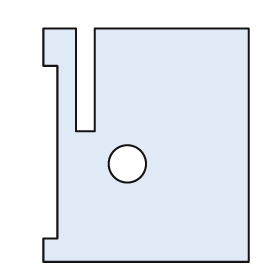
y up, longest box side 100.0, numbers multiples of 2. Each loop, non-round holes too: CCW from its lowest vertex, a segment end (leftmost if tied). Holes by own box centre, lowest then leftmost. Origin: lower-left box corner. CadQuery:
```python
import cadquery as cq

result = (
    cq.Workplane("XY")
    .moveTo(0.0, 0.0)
    .lineTo(88.0, 0.0)
    .lineTo(88.0, 100.0)
    .lineTo(22.0, 100.0)
    .lineTo(22.0, 56.0)
    .lineTo(14.0, 56.0)
    .lineTo(14.0, 100.0)
    .lineTo(0.0, 100.0)
    .lineTo(0.0, 84.0)
    .lineTo(6.0, 84.0)
    .lineTo(6.0, 10.0)
    .lineTo(0.0, 10.0)
    .close()
    .moveTo(36.0, 42.0)
    .circle(8.0)
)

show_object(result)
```